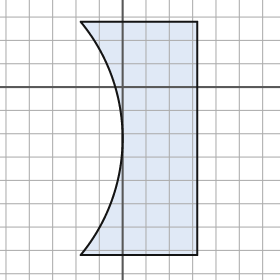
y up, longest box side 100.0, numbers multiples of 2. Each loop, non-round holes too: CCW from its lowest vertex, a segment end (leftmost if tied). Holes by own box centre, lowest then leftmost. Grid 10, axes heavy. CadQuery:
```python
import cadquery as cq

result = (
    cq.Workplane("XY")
    .moveTo(-18.0, -72.0)
    .lineTo(32.0, -72.0)
    .lineTo(32.0, 28.0)
    .lineTo(-18.0, 28.0)
    .threePointArc((0.0, -22.0), (-18.0, -72.0))
    .close()
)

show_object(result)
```